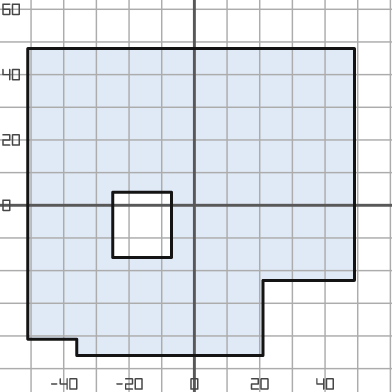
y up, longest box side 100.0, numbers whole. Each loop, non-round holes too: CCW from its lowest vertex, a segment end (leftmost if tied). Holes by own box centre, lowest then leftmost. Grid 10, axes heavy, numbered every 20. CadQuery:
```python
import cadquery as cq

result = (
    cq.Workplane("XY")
    .moveTo(-36.0, -46.0)
    .lineTo(21.0, -46.0)
    .lineTo(21.0, -23.0)
    .lineTo(49.0, -23.0)
    .lineTo(49.0, 48.0)
    .lineTo(-51.0, 48.0)
    .lineTo(-51.0, -41.0)
    .lineTo(-36.0, -41.0)
    .close()
    .moveTo(-25.0, -16.0)
    .lineTo(-7.0, -16.0)
    .lineTo(-7.0, 4.0)
    .lineTo(-25.0, 4.0)
    .close()
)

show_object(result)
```